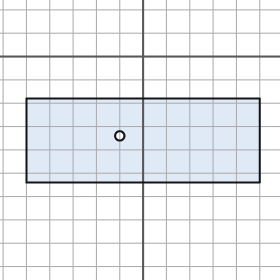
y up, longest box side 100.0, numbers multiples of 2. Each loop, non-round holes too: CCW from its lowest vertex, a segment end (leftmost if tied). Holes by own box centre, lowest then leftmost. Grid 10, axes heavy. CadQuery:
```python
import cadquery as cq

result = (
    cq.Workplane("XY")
    .moveTo(-50.0, -54.0)
    .lineTo(50.0, -54.0)
    .lineTo(50.0, -18.0)
    .lineTo(-50.0, -18.0)
    .close()
    .moveTo(-10.0, -34.0)
    .circle(2.0)
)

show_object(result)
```